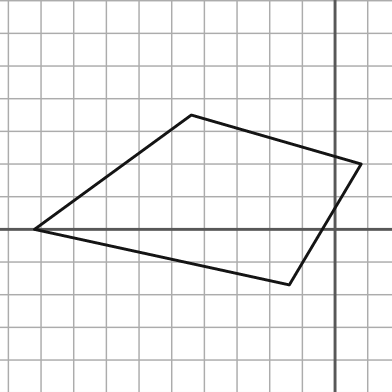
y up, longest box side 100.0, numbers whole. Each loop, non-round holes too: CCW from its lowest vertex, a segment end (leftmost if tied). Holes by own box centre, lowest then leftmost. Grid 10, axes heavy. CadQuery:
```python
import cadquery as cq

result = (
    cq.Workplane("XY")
    .moveTo(-14.0, -17.0)
    .lineTo(8.0, 20.0)
    .lineTo(-44.0, 35.0)
    .lineTo(-92.0, 0.0)
    .close()
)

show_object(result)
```